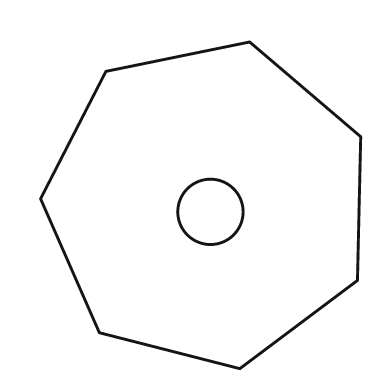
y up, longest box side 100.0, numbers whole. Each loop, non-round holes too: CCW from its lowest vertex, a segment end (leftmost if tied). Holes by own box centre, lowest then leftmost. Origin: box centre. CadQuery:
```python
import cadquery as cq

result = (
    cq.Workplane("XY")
    .moveTo(12.0, -50.0)
    .lineTo(48.0, -23.0)
    .lineTo(49.0, 21.0)
    .lineTo(15.0, 50.0)
    .lineTo(-29.0, 41.0)
    .lineTo(-49.0, 2.0)
    .lineTo(-31.0, -39.0)
    .close()
    .moveTo(3.0, -2.0)
    .circle(10.0)
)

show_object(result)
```